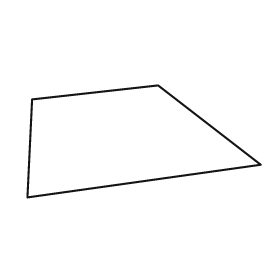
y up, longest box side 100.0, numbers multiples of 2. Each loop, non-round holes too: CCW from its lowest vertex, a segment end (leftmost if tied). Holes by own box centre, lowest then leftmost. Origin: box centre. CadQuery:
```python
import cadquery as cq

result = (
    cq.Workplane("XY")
    .moveTo(-50.0, -24.0)
    .lineTo(50.0, -10.0)
    .lineTo(6.0, 24.0)
    .lineTo(-48.0, 18.0)
    .close()
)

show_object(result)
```